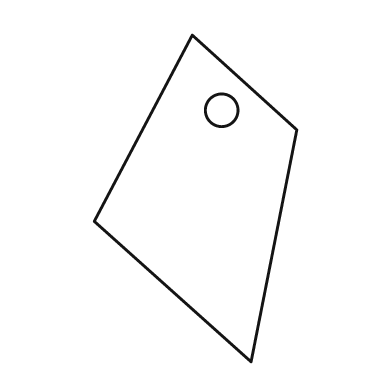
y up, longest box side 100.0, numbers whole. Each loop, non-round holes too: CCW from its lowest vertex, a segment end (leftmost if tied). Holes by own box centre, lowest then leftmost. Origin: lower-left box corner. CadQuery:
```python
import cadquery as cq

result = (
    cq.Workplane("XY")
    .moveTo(48.0, 0.0)
    .lineTo(62.0, 71.0)
    .lineTo(30.0, 100.0)
    .lineTo(0.0, 43.0)
    .close()
    .moveTo(39.0, 77.0)
    .circle(5.0)
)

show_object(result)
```